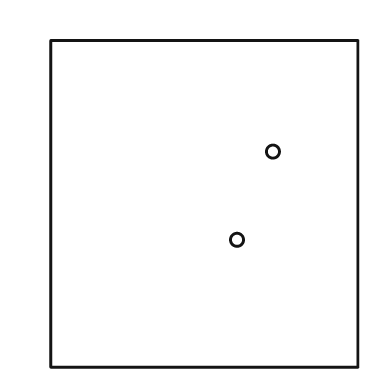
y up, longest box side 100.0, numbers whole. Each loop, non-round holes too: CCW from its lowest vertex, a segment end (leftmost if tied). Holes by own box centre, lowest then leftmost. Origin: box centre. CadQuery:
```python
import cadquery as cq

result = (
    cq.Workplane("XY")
    .moveTo(-47.0, -50.0)
    .lineTo(47.0, -50.0)
    .lineTo(47.0, 50.0)
    .lineTo(-47.0, 50.0)
    .close()
    .moveTo(10.0, -11.0)
    .circle(2.0)
    .moveTo(21.0, 16.0)
    .circle(2.0)
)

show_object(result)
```